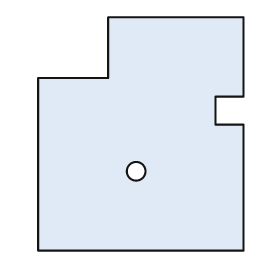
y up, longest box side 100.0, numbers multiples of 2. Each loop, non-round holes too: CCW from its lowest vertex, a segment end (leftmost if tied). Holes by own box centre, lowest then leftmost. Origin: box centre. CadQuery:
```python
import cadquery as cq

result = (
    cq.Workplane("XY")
    .moveTo(-44.0, -50.0)
    .lineTo(44.0, -50.0)
    .lineTo(44.0, 4.0)
    .lineTo(32.0, 4.0)
    .lineTo(32.0, 16.0)
    .lineTo(44.0, 16.0)
    .lineTo(44.0, 50.0)
    .lineTo(-14.0, 50.0)
    .lineTo(-14.0, 24.0)
    .lineTo(-44.0, 24.0)
    .close()
    .moveTo(-2.0, -16.0)
    .circle(4.0)
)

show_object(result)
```